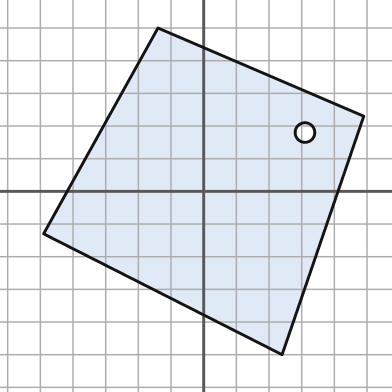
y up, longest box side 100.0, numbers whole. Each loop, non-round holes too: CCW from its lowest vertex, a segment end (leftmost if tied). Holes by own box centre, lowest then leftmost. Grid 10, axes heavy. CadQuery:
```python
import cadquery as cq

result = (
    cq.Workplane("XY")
    .moveTo(24.0, -50.0)
    .lineTo(49.0, 23.0)
    .lineTo(-14.0, 50.0)
    .lineTo(-49.0, -13.0)
    .close()
    .moveTo(31.0, 18.0)
    .circle(3.0)
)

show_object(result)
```